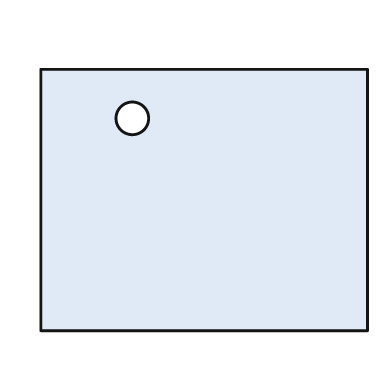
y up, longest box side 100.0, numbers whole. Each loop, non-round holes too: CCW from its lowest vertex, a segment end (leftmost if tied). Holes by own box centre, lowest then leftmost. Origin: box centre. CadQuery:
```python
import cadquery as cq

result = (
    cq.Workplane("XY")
    .moveTo(-50.0, -40.0)
    .lineTo(50.0, -40.0)
    .lineTo(50.0, 40.0)
    .lineTo(-50.0, 40.0)
    .close()
    .moveTo(-22.0, 25.0)
    .circle(5.0)
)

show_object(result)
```